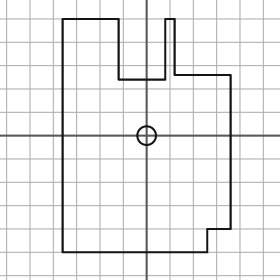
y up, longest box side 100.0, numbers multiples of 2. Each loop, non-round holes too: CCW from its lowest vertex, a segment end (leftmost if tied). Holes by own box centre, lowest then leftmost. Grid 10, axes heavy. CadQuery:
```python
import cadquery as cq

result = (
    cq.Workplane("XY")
    .moveTo(-36.0, -50.0)
    .lineTo(26.0, -50.0)
    .lineTo(26.0, -40.0)
    .lineTo(36.0, -40.0)
    .lineTo(36.0, 26.0)
    .lineTo(12.0, 26.0)
    .lineTo(12.0, 50.0)
    .lineTo(8.0, 50.0)
    .lineTo(8.0, 24.0)
    .lineTo(-12.0, 24.0)
    .lineTo(-12.0, 50.0)
    .lineTo(-36.0, 50.0)
    .close()
    .moveTo(0.0, 0.0)
    .circle(4.0)
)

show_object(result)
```